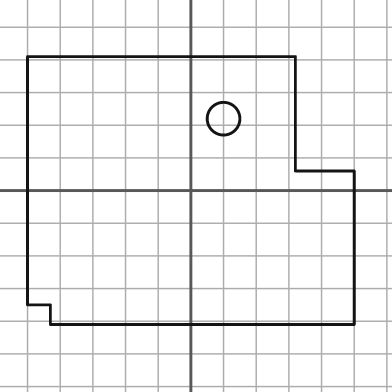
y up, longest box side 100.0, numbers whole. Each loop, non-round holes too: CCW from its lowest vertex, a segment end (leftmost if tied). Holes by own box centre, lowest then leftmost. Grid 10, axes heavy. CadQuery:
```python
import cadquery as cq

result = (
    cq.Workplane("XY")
    .moveTo(-43.0, -41.0)
    .lineTo(50.0, -41.0)
    .lineTo(50.0, 6.0)
    .lineTo(32.0, 6.0)
    .lineTo(32.0, 41.0)
    .lineTo(-50.0, 41.0)
    .lineTo(-50.0, -35.0)
    .lineTo(-43.0, -35.0)
    .close()
    .moveTo(10.0, 22.0)
    .circle(5.0)
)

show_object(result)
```